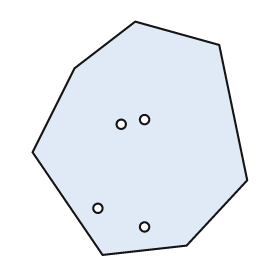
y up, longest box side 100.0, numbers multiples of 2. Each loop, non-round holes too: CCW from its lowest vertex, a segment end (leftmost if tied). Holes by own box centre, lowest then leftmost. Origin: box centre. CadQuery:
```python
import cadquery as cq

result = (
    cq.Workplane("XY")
    .moveTo(-16.0, -50.0)
    .lineTo(20.0, -46.0)
    .lineTo(46.0, -18.0)
    .lineTo(34.0, 40.0)
    .lineTo(-2.0, 50.0)
    .lineTo(-28.0, 30.0)
    .lineTo(-46.0, -6.0)
    .close()
    .moveTo(2.0, -38.0)
    .circle(2.0)
    .moveTo(-18.0, -30.0)
    .circle(2.0)
    .moveTo(-8.0, 6.0)
    .circle(2.0)
    .moveTo(2.0, 8.0)
    .circle(2.0)
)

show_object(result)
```